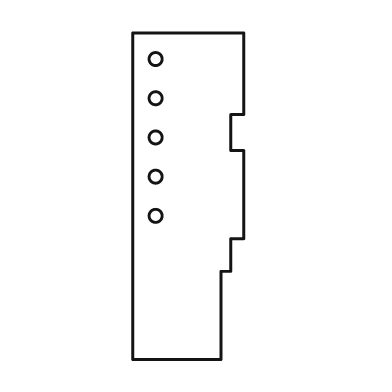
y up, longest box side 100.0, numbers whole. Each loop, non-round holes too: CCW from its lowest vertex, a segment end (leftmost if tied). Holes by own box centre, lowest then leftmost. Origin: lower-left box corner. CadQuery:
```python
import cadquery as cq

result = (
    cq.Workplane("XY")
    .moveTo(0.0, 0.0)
    .lineTo(27.0, 0.0)
    .lineTo(27.0, 27.0)
    .lineTo(30.0, 27.0)
    .lineTo(30.0, 37.0)
    .lineTo(34.0, 37.0)
    .lineTo(34.0, 64.0)
    .lineTo(30.0, 64.0)
    .lineTo(30.0, 75.0)
    .lineTo(34.0, 75.0)
    .lineTo(34.0, 100.0)
    .lineTo(0.0, 100.0)
    .close()
    .moveTo(7.0, 44.0)
    .circle(2.0)
    .moveTo(7.0, 56.0)
    .circle(2.0)
    .moveTo(7.0, 68.0)
    .circle(2.0)
    .moveTo(7.0, 80.0)
    .circle(2.0)
    .moveTo(7.0, 92.0)
    .circle(2.0)
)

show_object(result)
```